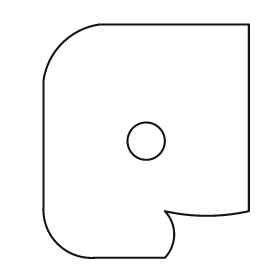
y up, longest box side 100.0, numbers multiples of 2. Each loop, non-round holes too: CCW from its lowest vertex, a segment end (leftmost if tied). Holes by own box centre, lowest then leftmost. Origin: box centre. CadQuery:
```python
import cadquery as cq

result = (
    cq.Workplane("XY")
    .moveTo(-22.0, -50.0)
    .lineTo(8.0, -50.0)
    .threePointArc((12.0, -40.0), (8.0, -30.0))
    .threePointArc((26.0, -32.0), (44.0, -30.0))
    .lineTo(44.0, 50.0)
    .lineTo(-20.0, 50.0)
    .threePointArc((-36.0, 42.0), (-44.0, 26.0))
    .lineTo(-44.0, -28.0)
    .threePointArc((-38.0, -44.0), (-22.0, -50.0))
    .close()
    .moveTo(0.0, 0.0)
    .circle(8.0)
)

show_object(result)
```